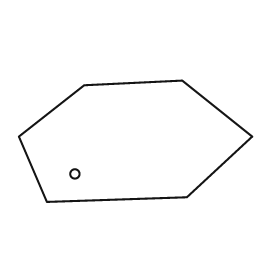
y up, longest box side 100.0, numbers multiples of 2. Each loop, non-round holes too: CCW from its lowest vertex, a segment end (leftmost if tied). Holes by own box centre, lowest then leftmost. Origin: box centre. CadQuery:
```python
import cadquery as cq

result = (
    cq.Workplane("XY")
    .moveTo(-38.0, -26.0)
    .lineTo(22.0, -24.0)
    .lineTo(50.0, 2.0)
    .lineTo(20.0, 26.0)
    .lineTo(-22.0, 24.0)
    .lineTo(-50.0, 2.0)
    .close()
    .moveTo(-26.0, -14.0)
    .circle(2.0)
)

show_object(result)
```